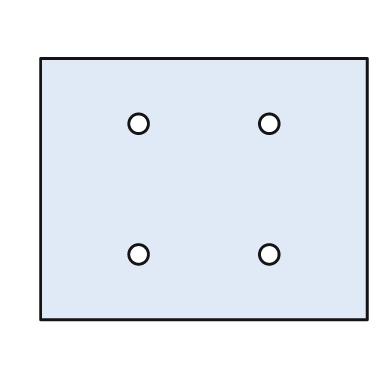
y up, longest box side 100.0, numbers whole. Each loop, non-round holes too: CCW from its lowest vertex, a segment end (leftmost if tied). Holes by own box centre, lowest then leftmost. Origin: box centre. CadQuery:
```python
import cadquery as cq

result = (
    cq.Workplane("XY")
    .moveTo(-50.0, -40.0)
    .lineTo(50.0, -40.0)
    .lineTo(50.0, 40.0)
    .lineTo(-50.0, 40.0)
    .close()
    .moveTo(-20.0, -20.0)
    .circle(3.0)
    .moveTo(20.0, -20.0)
    .circle(3.0)
    .moveTo(-20.0, 20.0)
    .circle(3.0)
    .moveTo(20.0, 20.0)
    .circle(3.0)
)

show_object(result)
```